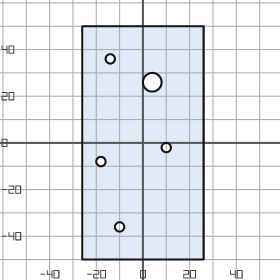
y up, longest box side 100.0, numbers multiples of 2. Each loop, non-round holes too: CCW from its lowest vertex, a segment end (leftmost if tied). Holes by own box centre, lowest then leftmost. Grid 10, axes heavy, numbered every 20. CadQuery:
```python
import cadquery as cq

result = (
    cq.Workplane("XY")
    .moveTo(-26.0, -50.0)
    .lineTo(26.0, -50.0)
    .lineTo(26.0, 50.0)
    .lineTo(-26.0, 50.0)
    .close()
    .moveTo(-10.0, -36.0)
    .circle(2.0)
    .moveTo(-18.0, -8.0)
    .circle(2.0)
    .moveTo(10.0, -2.0)
    .circle(2.0)
    .moveTo(4.0, 26.0)
    .circle(4.0)
    .moveTo(-14.0, 36.0)
    .circle(2.0)
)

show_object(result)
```